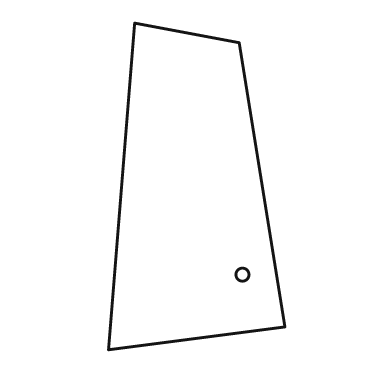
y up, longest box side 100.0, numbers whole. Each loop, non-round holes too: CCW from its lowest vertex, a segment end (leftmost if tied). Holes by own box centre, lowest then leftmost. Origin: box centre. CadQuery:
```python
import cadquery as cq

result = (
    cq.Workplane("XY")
    .moveTo(-27.0, -50.0)
    .lineTo(27.0, -43.0)
    .lineTo(13.0, 44.0)
    .lineTo(-19.0, 50.0)
    .close()
    .moveTo(14.0, -27.0)
    .circle(2.0)
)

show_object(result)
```